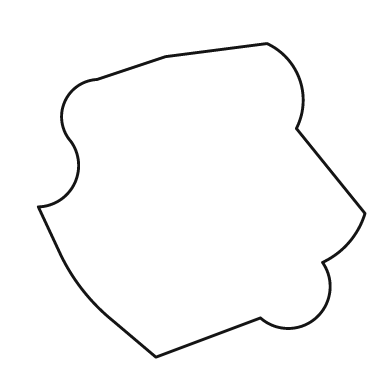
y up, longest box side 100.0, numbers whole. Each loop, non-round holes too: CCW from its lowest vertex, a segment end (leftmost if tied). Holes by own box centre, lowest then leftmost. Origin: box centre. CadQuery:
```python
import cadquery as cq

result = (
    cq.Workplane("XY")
    .moveTo(-14.0, -48.0)
    .lineTo(18.0, -36.0)
    .threePointArc((35.0, -36.0), (37.0, -19.0))
    .threePointArc((45.0, -13.0), (50.0, -4.0))
    .lineTo(29.0, 22.0)
    .threePointArc((30.0, 37.0), (20.0, 48.0))
    .lineTo(-11.0, 44.0)
    .lineTo(-32.0, 37.0)
    .threePointArc((-42.0, 30.0), (-40.0, 18.0))
    .threePointArc((-39.0, 5.0), (-50.0, -2.0))
    .lineTo(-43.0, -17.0)
    .threePointArc((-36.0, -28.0), (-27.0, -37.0))
    .close()
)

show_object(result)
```